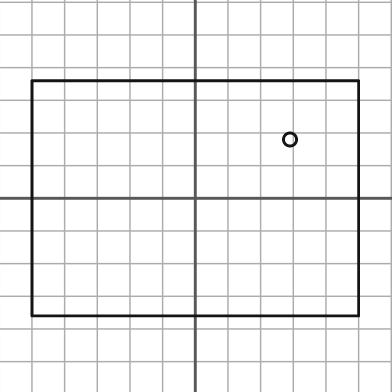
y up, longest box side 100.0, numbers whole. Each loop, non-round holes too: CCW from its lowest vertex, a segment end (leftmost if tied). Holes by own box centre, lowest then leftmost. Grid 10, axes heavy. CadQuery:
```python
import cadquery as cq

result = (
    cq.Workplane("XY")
    .moveTo(-50.0, -36.0)
    .lineTo(50.0, -36.0)
    .lineTo(50.0, 36.0)
    .lineTo(-50.0, 36.0)
    .close()
    .moveTo(29.0, 18.0)
    .circle(2.0)
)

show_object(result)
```